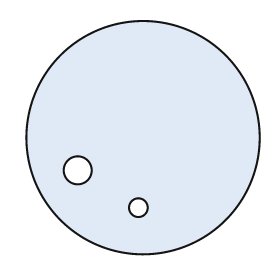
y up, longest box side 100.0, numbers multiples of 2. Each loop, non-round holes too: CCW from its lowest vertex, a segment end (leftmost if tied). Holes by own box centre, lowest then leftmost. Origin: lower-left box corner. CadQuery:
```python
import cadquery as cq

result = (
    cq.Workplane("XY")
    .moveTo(50.0, 50.0)
    .circle(50.0)
    .moveTo(48.0, 20.0)
    .circle(4.0)
    .moveTo(22.0, 36.0)
    .circle(6.0)
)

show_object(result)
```